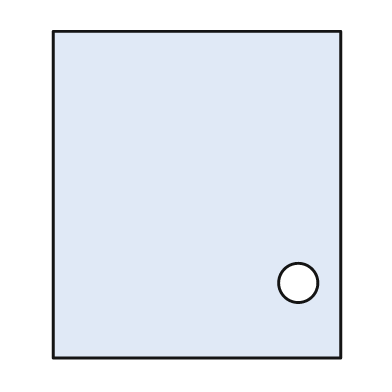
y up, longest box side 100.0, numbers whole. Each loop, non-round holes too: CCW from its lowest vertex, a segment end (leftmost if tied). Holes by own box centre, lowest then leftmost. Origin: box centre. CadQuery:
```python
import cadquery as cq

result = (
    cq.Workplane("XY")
    .moveTo(-44.0, -50.0)
    .lineTo(44.0, -50.0)
    .lineTo(44.0, 50.0)
    .lineTo(-44.0, 50.0)
    .close()
    .moveTo(31.0, -27.0)
    .circle(6.0)
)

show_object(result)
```